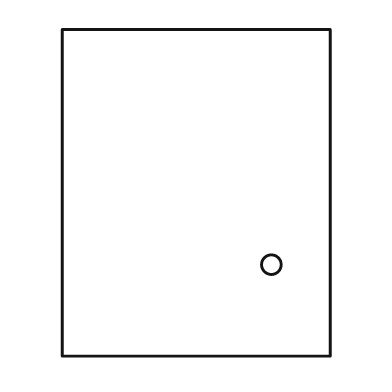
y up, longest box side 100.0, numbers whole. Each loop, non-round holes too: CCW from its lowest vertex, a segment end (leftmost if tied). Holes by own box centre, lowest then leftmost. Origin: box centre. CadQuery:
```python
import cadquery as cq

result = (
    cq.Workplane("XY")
    .moveTo(-41.0, -50.0)
    .lineTo(41.0, -50.0)
    .lineTo(41.0, 50.0)
    .lineTo(-41.0, 50.0)
    .close()
    .moveTo(23.0, -22.0)
    .circle(3.0)
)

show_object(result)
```